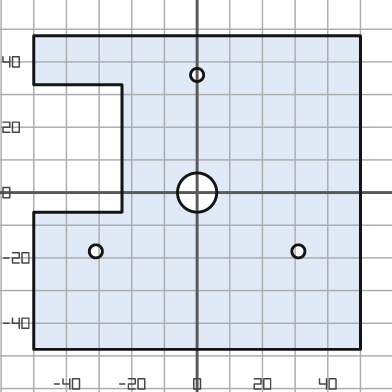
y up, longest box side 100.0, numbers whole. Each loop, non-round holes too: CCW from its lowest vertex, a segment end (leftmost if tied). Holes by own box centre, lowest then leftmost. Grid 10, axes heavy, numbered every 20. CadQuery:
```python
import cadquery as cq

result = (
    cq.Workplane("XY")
    .moveTo(-50.0, -48.0)
    .lineTo(50.0, -48.0)
    .lineTo(50.0, 48.0)
    .lineTo(-50.0, 48.0)
    .lineTo(-50.0, 33.0)
    .lineTo(-23.0, 33.0)
    .lineTo(-23.0, -6.0)
    .lineTo(-50.0, -6.0)
    .close()
    .moveTo(-31.0, -18.0)
    .circle(2.0)
    .moveTo(31.0, -18.0)
    .circle(2.0)
    .moveTo(0.0, 0.0)
    .circle(6.0)
    .moveTo(0.0, 36.0)
    .circle(2.0)
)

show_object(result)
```